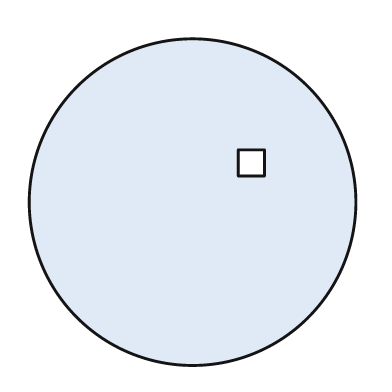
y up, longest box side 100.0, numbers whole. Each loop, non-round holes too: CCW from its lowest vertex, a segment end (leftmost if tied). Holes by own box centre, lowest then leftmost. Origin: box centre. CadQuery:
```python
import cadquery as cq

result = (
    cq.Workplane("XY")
    .moveTo(0.0, 0.0)
    .circle(50.0)
    .moveTo(14.0, 8.0)
    .lineTo(22.0, 8.0)
    .lineTo(22.0, 16.0)
    .lineTo(14.0, 16.0)
    .close()
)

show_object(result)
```